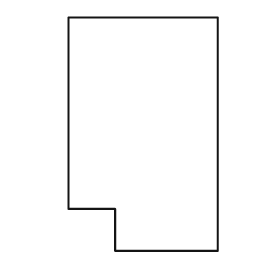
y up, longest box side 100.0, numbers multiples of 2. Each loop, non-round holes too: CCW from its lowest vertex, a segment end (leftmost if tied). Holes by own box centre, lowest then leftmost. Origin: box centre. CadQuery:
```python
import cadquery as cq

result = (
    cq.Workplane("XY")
    .moveTo(-12.0, -50.0)
    .lineTo(32.0, -50.0)
    .lineTo(32.0, 50.0)
    .lineTo(-32.0, 50.0)
    .lineTo(-32.0, -32.0)
    .lineTo(-12.0, -32.0)
    .close()
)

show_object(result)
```